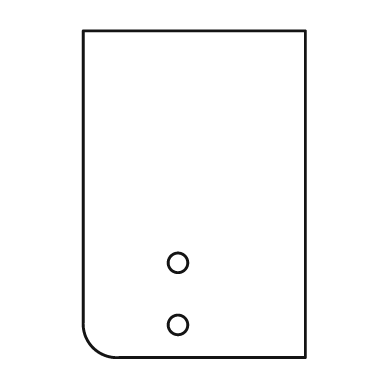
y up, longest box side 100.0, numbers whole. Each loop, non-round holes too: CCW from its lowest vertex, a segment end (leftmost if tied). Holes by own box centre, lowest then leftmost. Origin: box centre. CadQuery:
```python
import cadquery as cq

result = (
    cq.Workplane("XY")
    .moveTo(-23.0, -50.0)
    .lineTo(34.0, -50.0)
    .lineTo(34.0, 50.0)
    .lineTo(-34.0, 50.0)
    .lineTo(-34.0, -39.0)
    .threePointArc((-31.0, -47.0), (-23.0, -50.0))
    .close()
    .moveTo(-5.0, -40.0)
    .circle(3.0)
    .moveTo(-5.0, -21.0)
    .circle(3.0)
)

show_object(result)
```